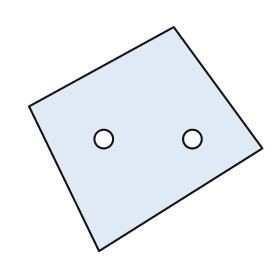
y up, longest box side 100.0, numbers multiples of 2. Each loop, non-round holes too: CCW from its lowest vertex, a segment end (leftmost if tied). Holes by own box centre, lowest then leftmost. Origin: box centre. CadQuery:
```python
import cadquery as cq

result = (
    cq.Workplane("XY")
    .moveTo(-20.0, -48.0)
    .lineTo(50.0, -4.0)
    .lineTo(12.0, 48.0)
    .lineTo(-50.0, 14.0)
    .close()
    .moveTo(-18.0, 0.0)
    .circle(4.0)
    .moveTo(20.0, 0.0)
    .circle(4.0)
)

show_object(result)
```